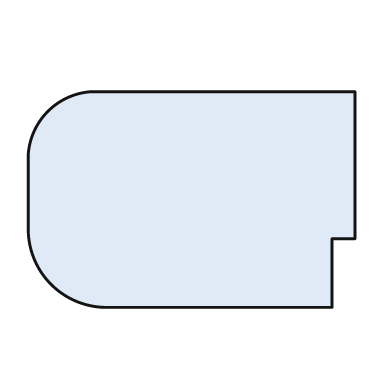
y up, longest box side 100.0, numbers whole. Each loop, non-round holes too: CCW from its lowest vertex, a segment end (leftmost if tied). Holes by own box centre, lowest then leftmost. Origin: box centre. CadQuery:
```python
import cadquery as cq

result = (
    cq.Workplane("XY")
    .moveTo(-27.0, -33.0)
    .lineTo(43.0, -33.0)
    .lineTo(43.0, -12.0)
    .lineTo(50.0, -12.0)
    .lineTo(50.0, 33.0)
    .lineTo(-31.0, 33.0)
    .threePointArc((-44.0, 27.0), (-50.0, 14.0))
    .lineTo(-50.0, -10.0)
    .threePointArc((-43.0, -26.0), (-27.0, -33.0))
    .close()
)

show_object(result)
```